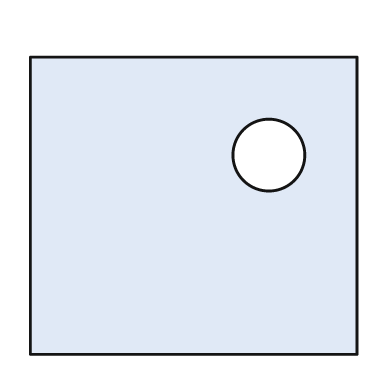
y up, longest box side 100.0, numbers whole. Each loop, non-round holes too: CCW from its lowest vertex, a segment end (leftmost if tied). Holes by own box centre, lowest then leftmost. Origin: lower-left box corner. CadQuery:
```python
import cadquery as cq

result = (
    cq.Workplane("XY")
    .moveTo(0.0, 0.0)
    .lineTo(100.0, 0.0)
    .lineTo(100.0, 91.0)
    .lineTo(0.0, 91.0)
    .close()
    .moveTo(73.0, 61.0)
    .circle(11.0)
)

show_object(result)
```